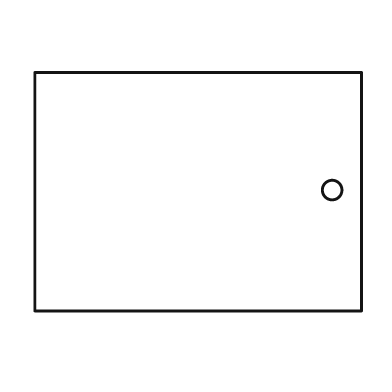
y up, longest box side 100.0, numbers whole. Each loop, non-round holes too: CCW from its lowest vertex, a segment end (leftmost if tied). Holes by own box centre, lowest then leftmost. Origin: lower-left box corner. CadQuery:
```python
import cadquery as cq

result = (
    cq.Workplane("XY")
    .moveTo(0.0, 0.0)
    .lineTo(100.0, 0.0)
    .lineTo(100.0, 73.0)
    .lineTo(0.0, 73.0)
    .close()
    .moveTo(91.0, 37.0)
    .circle(3.0)
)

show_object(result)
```